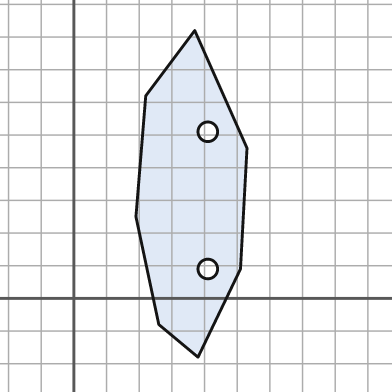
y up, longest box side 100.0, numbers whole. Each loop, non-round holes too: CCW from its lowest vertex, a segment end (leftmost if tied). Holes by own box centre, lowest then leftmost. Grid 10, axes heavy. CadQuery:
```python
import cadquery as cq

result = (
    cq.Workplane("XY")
    .moveTo(38.0, -18.0)
    .lineTo(51.0, 9.0)
    .lineTo(53.0, 46.0)
    .lineTo(37.0, 82.0)
    .lineTo(22.0, 62.0)
    .lineTo(19.0, 25.0)
    .lineTo(26.0, -8.0)
    .close()
    .moveTo(41.0, 9.0)
    .circle(3.0)
    .moveTo(41.0, 51.0)
    .circle(3.0)
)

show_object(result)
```